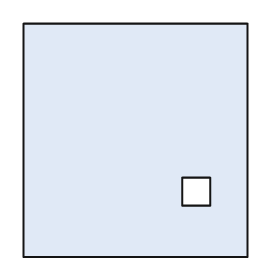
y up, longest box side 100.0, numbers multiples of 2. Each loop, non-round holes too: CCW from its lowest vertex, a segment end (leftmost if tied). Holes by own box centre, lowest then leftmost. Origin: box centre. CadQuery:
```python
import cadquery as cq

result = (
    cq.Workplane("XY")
    .moveTo(-48.0, -50.0)
    .lineTo(48.0, -50.0)
    .lineTo(48.0, 50.0)
    .lineTo(-48.0, 50.0)
    .close()
    .moveTo(20.0, -28.0)
    .lineTo(32.0, -28.0)
    .lineTo(32.0, -16.0)
    .lineTo(20.0, -16.0)
    .close()
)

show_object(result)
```